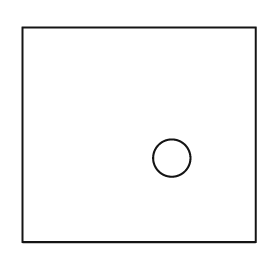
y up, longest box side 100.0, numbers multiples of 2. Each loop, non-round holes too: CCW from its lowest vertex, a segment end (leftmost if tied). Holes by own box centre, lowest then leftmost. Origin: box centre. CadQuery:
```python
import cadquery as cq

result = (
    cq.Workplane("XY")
    .moveTo(-50.0, -46.0)
    .lineTo(50.0, -46.0)
    .lineTo(50.0, 46.0)
    .lineTo(-50.0, 46.0)
    .close()
    .moveTo(14.0, -10.0)
    .circle(8.0)
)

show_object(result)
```